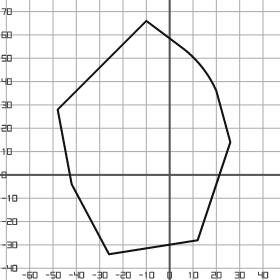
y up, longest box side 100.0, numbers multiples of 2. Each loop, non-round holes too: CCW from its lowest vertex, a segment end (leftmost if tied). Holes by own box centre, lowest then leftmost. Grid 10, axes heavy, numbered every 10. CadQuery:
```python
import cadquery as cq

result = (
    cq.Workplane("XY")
    .moveTo(-26.0, -34.0)
    .lineTo(12.0, -28.0)
    .lineTo(26.0, 14.0)
    .lineTo(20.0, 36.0)
    .threePointArc((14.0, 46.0), (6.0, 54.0))
    .lineTo(-10.0, 66.0)
    .lineTo(-48.0, 28.0)
    .lineTo(-42.0, -4.0)
    .close()
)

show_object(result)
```